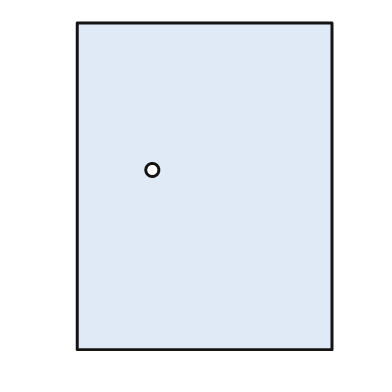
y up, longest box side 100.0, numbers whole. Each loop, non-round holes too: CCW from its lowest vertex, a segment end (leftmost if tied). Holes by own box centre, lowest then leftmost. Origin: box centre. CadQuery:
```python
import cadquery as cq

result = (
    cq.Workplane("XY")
    .moveTo(-39.0, -50.0)
    .lineTo(39.0, -50.0)
    .lineTo(39.0, 50.0)
    .lineTo(-39.0, 50.0)
    .close()
    .moveTo(-16.0, 5.0)
    .circle(2.0)
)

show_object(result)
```